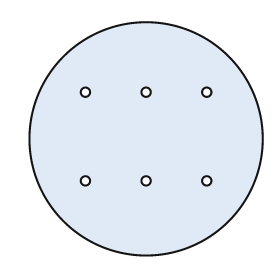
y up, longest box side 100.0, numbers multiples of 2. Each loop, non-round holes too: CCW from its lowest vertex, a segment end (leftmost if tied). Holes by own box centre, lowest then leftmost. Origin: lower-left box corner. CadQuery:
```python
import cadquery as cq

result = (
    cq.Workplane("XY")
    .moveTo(50.0, 50.0)
    .circle(50.0)
    .moveTo(24.0, 32.0)
    .circle(2.0)
    .moveTo(50.0, 32.0)
    .circle(2.0)
    .moveTo(76.0, 32.0)
    .circle(2.0)
    .moveTo(24.0, 70.0)
    .circle(2.0)
    .moveTo(50.0, 70.0)
    .circle(2.0)
    .moveTo(76.0, 70.0)
    .circle(2.0)
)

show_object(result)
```